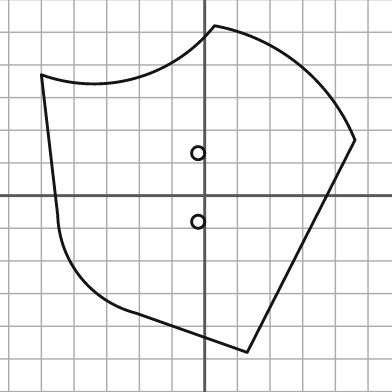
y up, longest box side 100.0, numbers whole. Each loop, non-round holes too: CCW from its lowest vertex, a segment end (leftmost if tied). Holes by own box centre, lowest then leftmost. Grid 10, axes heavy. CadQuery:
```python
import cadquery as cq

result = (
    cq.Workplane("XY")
    .moveTo(13.0, -48.0)
    .lineTo(46.0, 17.0)
    .threePointArc((29.0, 40.0), (3.0, 52.0))
    .threePointArc((-21.0, 36.0), (-50.0, 37.0))
    .lineTo(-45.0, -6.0)
    .threePointArc((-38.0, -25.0), (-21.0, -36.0))
    .close()
    .moveTo(-2.0, -8.0)
    .circle(2.0)
    .moveTo(-2.0, 13.0)
    .circle(2.0)
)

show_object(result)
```